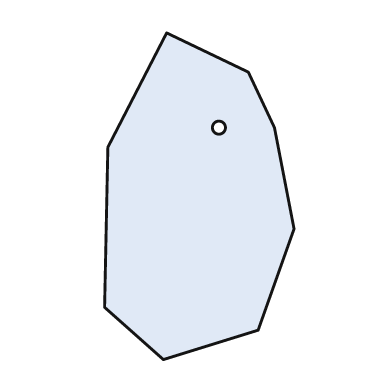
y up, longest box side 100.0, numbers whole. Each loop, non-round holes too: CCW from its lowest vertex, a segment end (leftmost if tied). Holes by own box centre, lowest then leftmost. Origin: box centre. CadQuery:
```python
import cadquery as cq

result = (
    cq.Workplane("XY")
    .moveTo(-11.0, -50.0)
    .lineTo(18.0, -41.0)
    .lineTo(29.0, -10.0)
    .lineTo(23.0, 21.0)
    .lineTo(15.0, 38.0)
    .lineTo(-10.0, 50.0)
    .lineTo(-28.0, 15.0)
    .lineTo(-29.0, -34.0)
    .close()
    .moveTo(6.0, 21.0)
    .circle(2.0)
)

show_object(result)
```